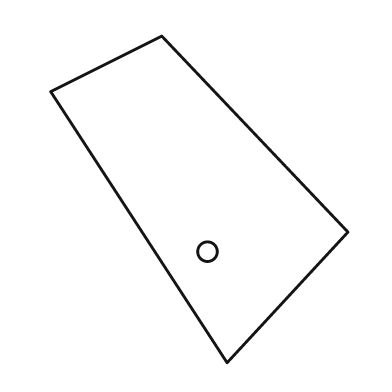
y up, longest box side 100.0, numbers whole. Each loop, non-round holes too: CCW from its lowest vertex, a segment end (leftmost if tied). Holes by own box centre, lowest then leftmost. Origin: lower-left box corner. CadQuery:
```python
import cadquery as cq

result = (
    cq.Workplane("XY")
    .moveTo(54.0, 0.0)
    .lineTo(91.0, 40.0)
    .lineTo(34.0, 100.0)
    .lineTo(0.0, 83.0)
    .close()
    .moveTo(48.0, 34.0)
    .circle(3.0)
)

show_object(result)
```